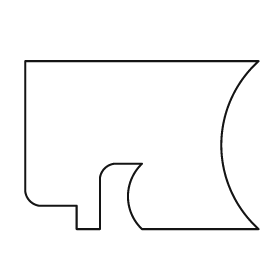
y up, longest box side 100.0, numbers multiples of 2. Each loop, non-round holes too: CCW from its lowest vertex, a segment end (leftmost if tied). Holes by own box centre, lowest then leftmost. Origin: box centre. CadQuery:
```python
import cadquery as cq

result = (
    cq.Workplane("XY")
    .moveTo(-28.0, -36.0)
    .lineTo(-18.0, -36.0)
    .lineTo(-18.0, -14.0)
    .threePointArc((-16.0, -10.0), (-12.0, -8.0))
    .lineTo(0.0, -8.0)
    .threePointArc((-6.0, -22.0), (0.0, -36.0))
    .lineTo(50.0, -36.0)
    .threePointArc((34.0, 0.0), (50.0, 36.0))
    .lineTo(-50.0, 36.0)
    .lineTo(-50.0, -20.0)
    .threePointArc((-48.0, -24.0), (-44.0, -26.0))
    .lineTo(-28.0, -26.0)
    .close()
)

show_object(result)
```